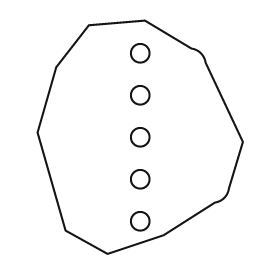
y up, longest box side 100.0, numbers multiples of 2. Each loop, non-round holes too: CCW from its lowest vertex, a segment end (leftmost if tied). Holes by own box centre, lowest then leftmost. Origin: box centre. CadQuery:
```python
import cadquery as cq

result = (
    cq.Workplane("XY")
    .moveTo(-14.0, -50.0)
    .lineTo(10.0, -42.0)
    .lineTo(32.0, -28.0)
    .threePointArc((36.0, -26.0), (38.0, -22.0))
    .lineTo(44.0, -2.0)
    .lineTo(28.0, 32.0)
    .threePointArc((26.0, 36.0), (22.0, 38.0))
    .lineTo(2.0, 50.0)
    .lineTo(-22.0, 48.0)
    .lineTo(-36.0, 30.0)
    .lineTo(-44.0, 2.0)
    .lineTo(-32.0, -40.0)
    .close()
    .moveTo(0.0, -36.0)
    .circle(4.0)
    .moveTo(0.0, -18.0)
    .circle(4.0)
    .moveTo(0.0, 0.0)
    .circle(4.0)
    .moveTo(0.0, 18.0)
    .circle(4.0)
    .moveTo(0.0, 36.0)
    .circle(4.0)
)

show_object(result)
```